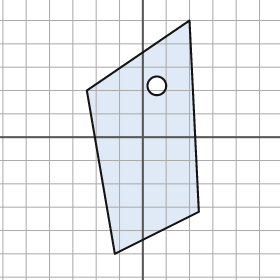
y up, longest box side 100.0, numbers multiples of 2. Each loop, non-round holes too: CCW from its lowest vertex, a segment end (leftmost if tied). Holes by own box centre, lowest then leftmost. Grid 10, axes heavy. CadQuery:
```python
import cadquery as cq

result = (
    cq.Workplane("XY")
    .moveTo(-12.0, -50.0)
    .lineTo(24.0, -32.0)
    .lineTo(20.0, 50.0)
    .lineTo(-24.0, 20.0)
    .close()
    .moveTo(6.0, 22.0)
    .circle(4.0)
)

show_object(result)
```